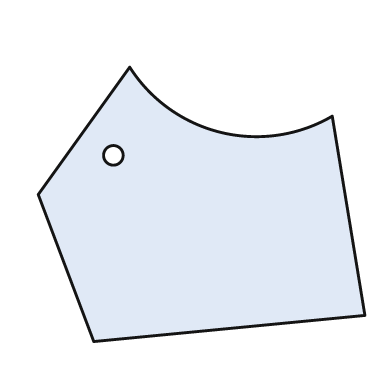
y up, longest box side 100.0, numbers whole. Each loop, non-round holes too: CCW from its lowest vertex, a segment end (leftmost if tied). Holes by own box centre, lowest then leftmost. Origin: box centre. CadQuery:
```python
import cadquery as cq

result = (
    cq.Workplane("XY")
    .moveTo(-33.0, -42.0)
    .lineTo(50.0, -34.0)
    .lineTo(40.0, 27.0)
    .threePointArc((6.0, 22.0), (-22.0, 42.0))
    .lineTo(-50.0, 3.0)
    .close()
    .moveTo(-27.0, 15.0)
    .circle(3.0)
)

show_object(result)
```